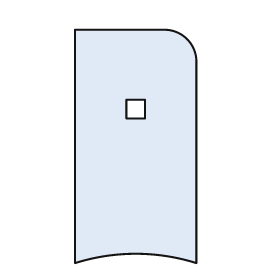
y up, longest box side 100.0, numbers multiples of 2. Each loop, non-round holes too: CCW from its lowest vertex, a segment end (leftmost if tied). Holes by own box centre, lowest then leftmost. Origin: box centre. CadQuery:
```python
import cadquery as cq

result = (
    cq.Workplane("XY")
    .moveTo(-26.0, -50.0)
    .threePointArc((0.0, -46.0), (26.0, -50.0))
    .lineTo(26.0, 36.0)
    .threePointArc((22.0, 46.0), (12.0, 50.0))
    .lineTo(-26.0, 50.0)
    .close()
    .moveTo(-4.0, 12.0)
    .lineTo(4.0, 12.0)
    .lineTo(4.0, 20.0)
    .lineTo(-4.0, 20.0)
    .close()
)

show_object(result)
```